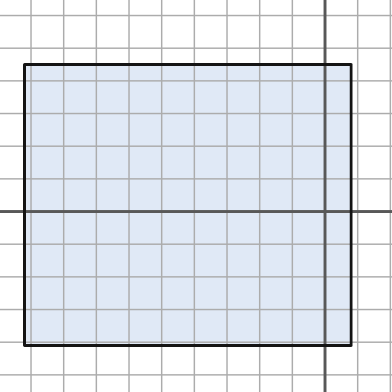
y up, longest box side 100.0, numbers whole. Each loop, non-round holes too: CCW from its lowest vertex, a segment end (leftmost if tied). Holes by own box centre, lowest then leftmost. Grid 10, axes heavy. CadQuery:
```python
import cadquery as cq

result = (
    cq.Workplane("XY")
    .moveTo(-92.0, -41.0)
    .lineTo(8.0, -41.0)
    .lineTo(8.0, 45.0)
    .lineTo(-92.0, 45.0)
    .close()
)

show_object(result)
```